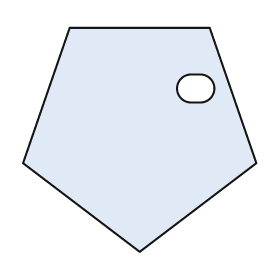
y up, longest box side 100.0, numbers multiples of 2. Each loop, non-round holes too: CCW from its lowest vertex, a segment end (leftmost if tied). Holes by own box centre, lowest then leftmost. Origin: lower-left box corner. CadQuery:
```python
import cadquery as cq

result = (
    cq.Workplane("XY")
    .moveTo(50.0, 0.0)
    .lineTo(100.0, 38.0)
    .lineTo(80.0, 96.0)
    .lineTo(20.0, 96.0)
    .lineTo(0.0, 38.0)
    .close()
    .moveTo(72.0, 64.0)
    .lineTo(76.0, 64.0)
    .threePointArc((82.0, 70.0), (76.0, 76.0))
    .lineTo(72.0, 76.0)
    .threePointArc((66.0, 70.0), (72.0, 64.0))
    .close()
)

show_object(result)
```